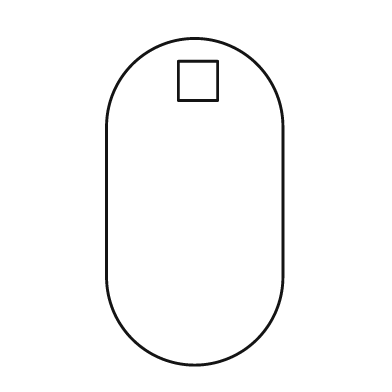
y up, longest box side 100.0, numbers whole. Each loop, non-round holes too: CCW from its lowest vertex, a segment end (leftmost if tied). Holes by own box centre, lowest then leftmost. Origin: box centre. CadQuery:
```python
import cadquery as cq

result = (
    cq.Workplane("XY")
    .moveTo(-27.0, -23.0)
    .threePointArc((0.0, -50.0), (27.0, -23.0))
    .lineTo(27.0, 23.0)
    .threePointArc((0.0, 50.0), (-27.0, 23.0))
    .close()
    .moveTo(-5.0, 31.0)
    .lineTo(7.0, 31.0)
    .lineTo(7.0, 43.0)
    .lineTo(-5.0, 43.0)
    .close()
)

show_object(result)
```